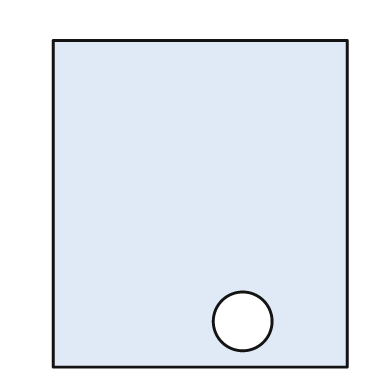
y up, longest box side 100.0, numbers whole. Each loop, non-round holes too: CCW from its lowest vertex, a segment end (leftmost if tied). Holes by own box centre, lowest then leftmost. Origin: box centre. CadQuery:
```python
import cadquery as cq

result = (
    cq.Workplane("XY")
    .moveTo(-45.0, -50.0)
    .lineTo(45.0, -50.0)
    .lineTo(45.0, 50.0)
    .lineTo(-45.0, 50.0)
    .close()
    .moveTo(13.0, -36.0)
    .circle(9.0)
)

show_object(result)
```